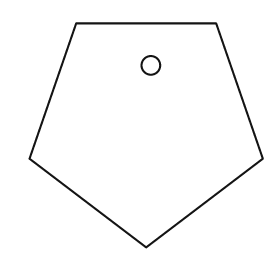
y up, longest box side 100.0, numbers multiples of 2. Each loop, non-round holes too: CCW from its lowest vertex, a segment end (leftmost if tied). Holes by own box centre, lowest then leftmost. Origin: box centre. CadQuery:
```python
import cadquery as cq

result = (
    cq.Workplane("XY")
    .moveTo(0.0, -48.0)
    .lineTo(50.0, -10.0)
    .lineTo(30.0, 48.0)
    .lineTo(-30.0, 48.0)
    .lineTo(-50.0, -10.0)
    .close()
    .moveTo(2.0, 30.0)
    .circle(4.0)
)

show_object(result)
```